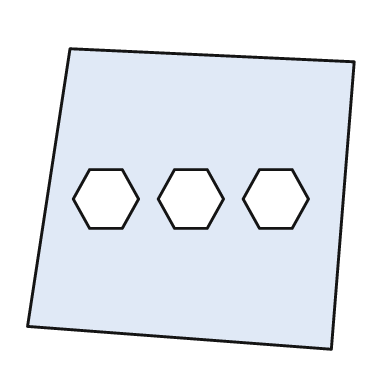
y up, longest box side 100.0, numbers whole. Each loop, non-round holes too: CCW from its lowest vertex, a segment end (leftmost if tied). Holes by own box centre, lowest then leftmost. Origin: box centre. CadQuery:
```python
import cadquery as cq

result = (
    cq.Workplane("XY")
    .moveTo(43.0, -46.0)
    .lineTo(50.0, 42.0)
    .lineTo(-37.0, 46.0)
    .lineTo(-50.0, -39.0)
    .close()
    .moveTo(-31.0, -9.0)
    .lineTo(-21.0, -9.0)
    .lineTo(-16.0, 0.0)
    .lineTo(-21.0, 9.0)
    .lineTo(-31.0, 9.0)
    .lineTo(-36.0, 0.0)
    .close()
    .moveTo(-5.0, -9.0)
    .lineTo(5.0, -9.0)
    .lineTo(10.0, 0.0)
    .lineTo(5.0, 9.0)
    .lineTo(-5.0, 9.0)
    .lineTo(-10.0, 0.0)
    .close()
    .moveTo(21.0, -9.0)
    .lineTo(31.0, -9.0)
    .lineTo(36.0, 0.0)
    .lineTo(31.0, 9.0)
    .lineTo(21.0, 9.0)
    .lineTo(16.0, 0.0)
    .close()
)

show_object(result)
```